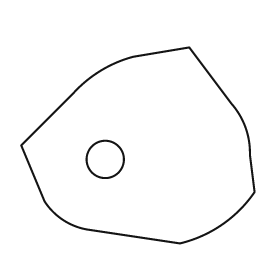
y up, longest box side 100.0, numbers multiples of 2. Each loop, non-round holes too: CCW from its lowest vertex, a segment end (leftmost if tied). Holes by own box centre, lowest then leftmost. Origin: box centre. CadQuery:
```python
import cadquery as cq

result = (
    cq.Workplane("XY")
    .moveTo(18.0, -42.0)
    .threePointArc((36.0, -34.0), (50.0, -20.0))
    .lineTo(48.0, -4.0)
    .threePointArc((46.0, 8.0), (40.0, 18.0))
    .lineTo(22.0, 42.0)
    .lineTo(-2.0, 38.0)
    .threePointArc((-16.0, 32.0), (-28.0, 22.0))
    .lineTo(-50.0, 0.0)
    .lineTo(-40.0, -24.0)
    .threePointArc((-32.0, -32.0), (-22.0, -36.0))
    .close()
    .moveTo(-14.0, -6.0)
    .circle(8.0)
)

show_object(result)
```